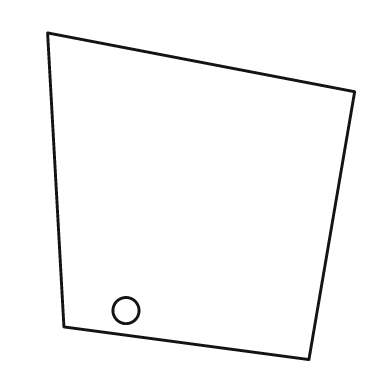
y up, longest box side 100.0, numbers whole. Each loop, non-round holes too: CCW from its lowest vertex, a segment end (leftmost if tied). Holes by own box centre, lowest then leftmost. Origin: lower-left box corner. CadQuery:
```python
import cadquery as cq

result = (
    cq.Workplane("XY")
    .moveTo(80.0, 0.0)
    .lineTo(94.0, 82.0)
    .lineTo(0.0, 100.0)
    .lineTo(5.0, 10.0)
    .close()
    .moveTo(24.0, 15.0)
    .circle(4.0)
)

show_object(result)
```